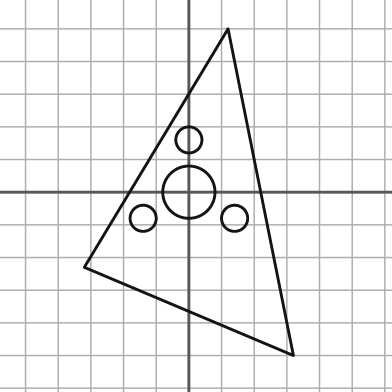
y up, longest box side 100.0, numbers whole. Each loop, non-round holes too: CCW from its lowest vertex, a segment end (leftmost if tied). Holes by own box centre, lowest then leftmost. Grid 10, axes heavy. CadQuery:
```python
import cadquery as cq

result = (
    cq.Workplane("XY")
    .moveTo(32.0, -50.0)
    .lineTo(12.0, 50.0)
    .lineTo(-32.0, -23.0)
    .close()
    .moveTo(-14.0, -8.0)
    .circle(4.0)
    .moveTo(14.0, -8.0)
    .circle(4.0)
    .moveTo(0.0, 0.0)
    .circle(8.0)
    .moveTo(0.0, 16.0)
    .circle(4.0)
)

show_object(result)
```